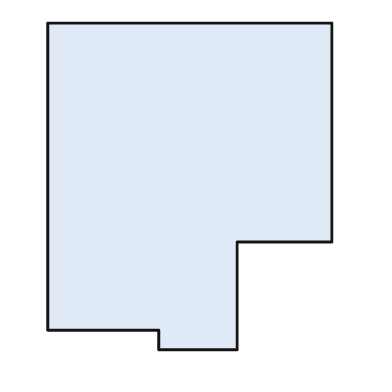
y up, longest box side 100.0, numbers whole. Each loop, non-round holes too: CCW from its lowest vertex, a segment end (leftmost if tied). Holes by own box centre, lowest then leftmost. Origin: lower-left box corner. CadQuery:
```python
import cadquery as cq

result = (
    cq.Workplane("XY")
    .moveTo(34.0, 0.0)
    .lineTo(58.0, 0.0)
    .lineTo(58.0, 33.0)
    .lineTo(87.0, 33.0)
    .lineTo(87.0, 100.0)
    .lineTo(0.0, 100.0)
    .lineTo(0.0, 6.0)
    .lineTo(34.0, 6.0)
    .close()
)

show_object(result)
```